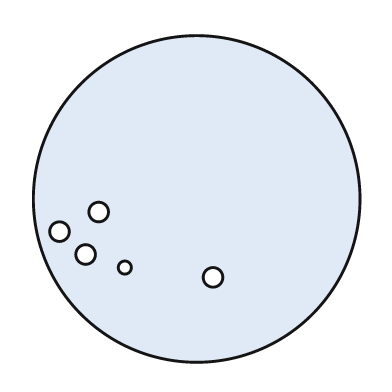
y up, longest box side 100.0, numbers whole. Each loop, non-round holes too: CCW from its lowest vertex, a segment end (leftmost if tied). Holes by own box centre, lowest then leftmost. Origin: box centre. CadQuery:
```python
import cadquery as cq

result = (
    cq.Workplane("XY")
    .moveTo(0.0, 0.0)
    .circle(50.0)
    .moveTo(5.0, -24.0)
    .circle(3.0)
    .moveTo(-22.0, -21.0)
    .circle(2.0)
    .moveTo(-34.0, -17.0)
    .circle(3.0)
    .moveTo(-42.0, -10.0)
    .circle(3.0)
    .moveTo(-30.0, -4.0)
    .circle(3.0)
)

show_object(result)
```